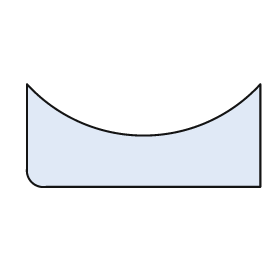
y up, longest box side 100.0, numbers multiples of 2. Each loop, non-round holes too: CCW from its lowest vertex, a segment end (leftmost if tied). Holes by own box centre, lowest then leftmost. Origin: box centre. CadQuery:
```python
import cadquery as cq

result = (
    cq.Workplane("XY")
    .moveTo(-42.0, -22.0)
    .lineTo(50.0, -22.0)
    .lineTo(50.0, 22.0)
    .threePointArc((0.0, 0.0), (-50.0, 22.0))
    .lineTo(-50.0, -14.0)
    .threePointArc((-48.0, -20.0), (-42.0, -22.0))
    .close()
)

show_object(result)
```